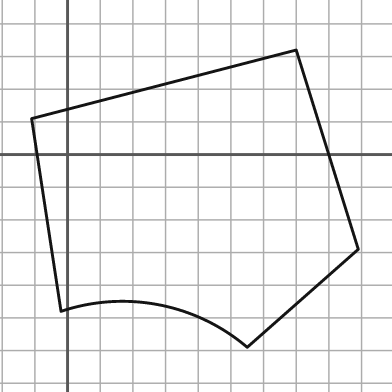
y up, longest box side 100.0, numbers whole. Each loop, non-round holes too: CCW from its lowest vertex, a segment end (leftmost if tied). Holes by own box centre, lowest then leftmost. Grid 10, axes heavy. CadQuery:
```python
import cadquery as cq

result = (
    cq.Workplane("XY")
    .moveTo(55.0, -59.0)
    .lineTo(89.0, -29.0)
    .lineTo(70.0, 32.0)
    .lineTo(-11.0, 11.0)
    .lineTo(-2.0, -48.0)
    .threePointArc((28.0, -46.0), (55.0, -59.0))
    .close()
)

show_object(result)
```